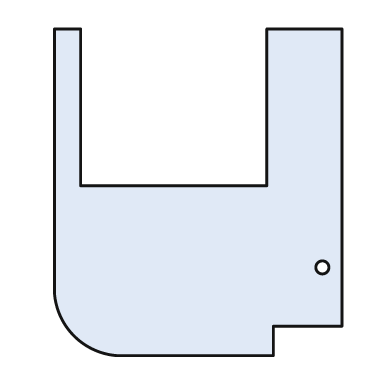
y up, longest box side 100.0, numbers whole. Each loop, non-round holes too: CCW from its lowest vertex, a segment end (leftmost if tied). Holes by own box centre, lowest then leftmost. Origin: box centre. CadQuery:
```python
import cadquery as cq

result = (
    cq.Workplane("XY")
    .moveTo(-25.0, -50.0)
    .lineTo(23.0, -50.0)
    .lineTo(23.0, -41.0)
    .lineTo(44.0, -41.0)
    .lineTo(44.0, 50.0)
    .lineTo(21.0, 50.0)
    .lineTo(21.0, 2.0)
    .lineTo(-36.0, 2.0)
    .lineTo(-36.0, 50.0)
    .lineTo(-44.0, 50.0)
    .lineTo(-44.0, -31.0)
    .threePointArc((-38.0, -44.0), (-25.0, -50.0))
    .close()
    .moveTo(38.0, -23.0)
    .circle(2.0)
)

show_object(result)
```